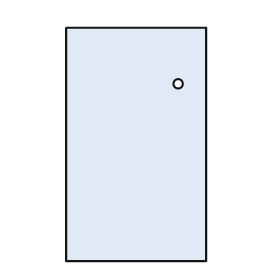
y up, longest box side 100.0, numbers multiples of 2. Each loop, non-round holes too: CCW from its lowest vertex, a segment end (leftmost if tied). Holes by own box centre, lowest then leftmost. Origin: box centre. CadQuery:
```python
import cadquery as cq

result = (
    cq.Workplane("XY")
    .moveTo(-30.0, -50.0)
    .lineTo(30.0, -50.0)
    .lineTo(30.0, 50.0)
    .lineTo(-30.0, 50.0)
    .close()
    .moveTo(18.0, 26.0)
    .circle(2.0)
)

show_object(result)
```